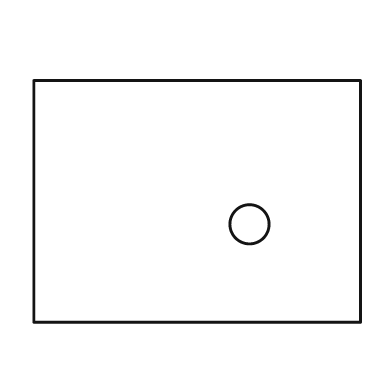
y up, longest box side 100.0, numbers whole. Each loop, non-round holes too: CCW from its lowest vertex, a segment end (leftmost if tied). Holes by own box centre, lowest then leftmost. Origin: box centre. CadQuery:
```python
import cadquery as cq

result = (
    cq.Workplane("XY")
    .moveTo(-50.0, -37.0)
    .lineTo(50.0, -37.0)
    .lineTo(50.0, 37.0)
    .lineTo(-50.0, 37.0)
    .close()
    .moveTo(16.0, -7.0)
    .circle(6.0)
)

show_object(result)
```